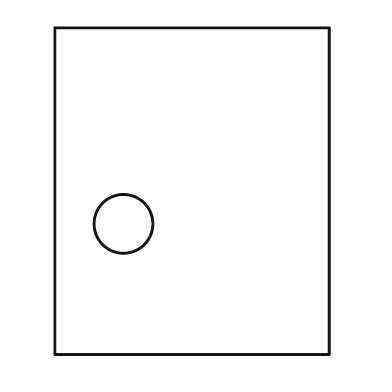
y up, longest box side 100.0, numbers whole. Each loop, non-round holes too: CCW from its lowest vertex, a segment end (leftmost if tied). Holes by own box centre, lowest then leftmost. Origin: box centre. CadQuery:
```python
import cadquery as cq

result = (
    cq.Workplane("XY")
    .moveTo(-42.0, -50.0)
    .lineTo(42.0, -50.0)
    .lineTo(42.0, 50.0)
    .lineTo(-42.0, 50.0)
    .close()
    .moveTo(-21.0, -10.0)
    .circle(9.0)
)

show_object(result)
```